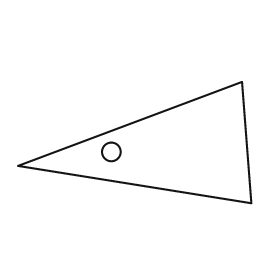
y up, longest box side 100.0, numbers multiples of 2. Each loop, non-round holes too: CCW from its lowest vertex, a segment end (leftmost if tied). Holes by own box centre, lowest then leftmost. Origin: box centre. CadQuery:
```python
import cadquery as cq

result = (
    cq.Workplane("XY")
    .moveTo(50.0, -26.0)
    .lineTo(46.0, 26.0)
    .lineTo(-50.0, -10.0)
    .close()
    .moveTo(-10.0, -4.0)
    .circle(4.0)
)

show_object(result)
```